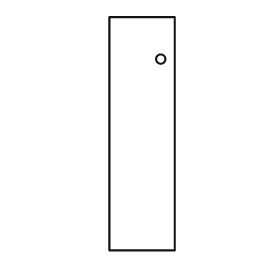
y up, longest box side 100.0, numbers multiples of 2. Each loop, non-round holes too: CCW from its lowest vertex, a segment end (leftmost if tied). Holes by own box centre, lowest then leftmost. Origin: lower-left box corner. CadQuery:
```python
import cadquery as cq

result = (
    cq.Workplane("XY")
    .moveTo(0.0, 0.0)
    .lineTo(28.0, 0.0)
    .lineTo(28.0, 100.0)
    .lineTo(0.0, 100.0)
    .close()
    .moveTo(22.0, 82.0)
    .circle(2.0)
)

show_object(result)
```